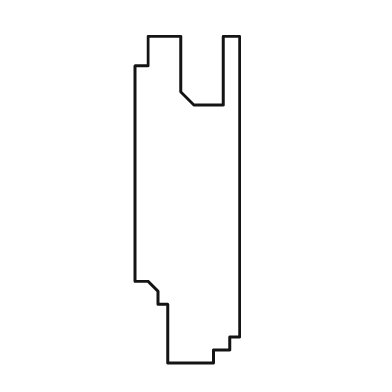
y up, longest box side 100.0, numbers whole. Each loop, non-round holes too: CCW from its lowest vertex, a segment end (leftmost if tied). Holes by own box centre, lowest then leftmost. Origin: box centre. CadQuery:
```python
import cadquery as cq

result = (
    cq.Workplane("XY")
    .moveTo(-6.0, -50.0)
    .lineTo(8.0, -50.0)
    .lineTo(8.0, -46.0)
    .lineTo(13.0, -46.0)
    .lineTo(13.0, -42.0)
    .lineTo(16.0, -42.0)
    .lineTo(16.0, 50.0)
    .lineTo(11.0, 50.0)
    .lineTo(11.0, 29.0)
    .lineTo(2.0, 29.0)
    .lineTo(-2.0, 33.0)
    .lineTo(-2.0, 50.0)
    .lineTo(-12.0, 50.0)
    .lineTo(-12.0, 41.0)
    .lineTo(-16.0, 41.0)
    .lineTo(-16.0, -25.0)
    .lineTo(-12.0, -25.0)
    .lineTo(-9.0, -28.0)
    .lineTo(-9.0, -32.0)
    .lineTo(-6.0, -32.0)
    .close()
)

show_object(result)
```